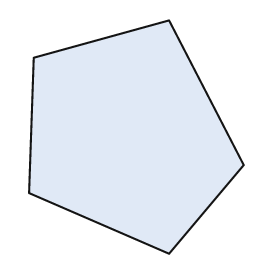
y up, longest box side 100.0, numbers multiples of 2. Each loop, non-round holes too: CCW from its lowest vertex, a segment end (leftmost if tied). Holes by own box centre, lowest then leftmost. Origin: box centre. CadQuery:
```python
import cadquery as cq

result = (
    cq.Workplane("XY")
    .moveTo(14.0, -50.0)
    .lineTo(46.0, -12.0)
    .lineTo(14.0, 50.0)
    .lineTo(-44.0, 34.0)
    .lineTo(-46.0, -24.0)
    .close()
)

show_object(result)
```